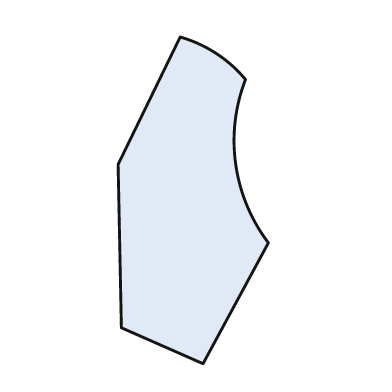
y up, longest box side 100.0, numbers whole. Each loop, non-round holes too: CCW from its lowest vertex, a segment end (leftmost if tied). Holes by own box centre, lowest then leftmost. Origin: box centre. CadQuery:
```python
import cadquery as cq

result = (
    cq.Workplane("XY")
    .moveTo(3.0, -50.0)
    .lineTo(23.0, -13.0)
    .threePointArc((13.0, 11.0), (16.0, 37.0))
    .threePointArc((7.0, 45.0), (-4.0, 50.0))
    .lineTo(-23.0, 11.0)
    .lineTo(-22.0, -39.0)
    .close()
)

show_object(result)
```